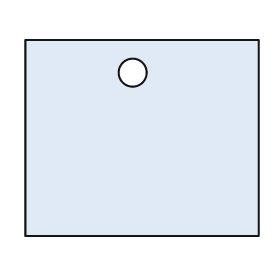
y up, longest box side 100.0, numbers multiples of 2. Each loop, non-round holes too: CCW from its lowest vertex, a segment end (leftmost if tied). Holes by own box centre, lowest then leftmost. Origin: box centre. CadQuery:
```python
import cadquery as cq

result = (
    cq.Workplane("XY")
    .moveTo(-50.0, -42.0)
    .lineTo(50.0, -42.0)
    .lineTo(50.0, 42.0)
    .lineTo(-50.0, 42.0)
    .close()
    .moveTo(-4.0, 28.0)
    .circle(6.0)
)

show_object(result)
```